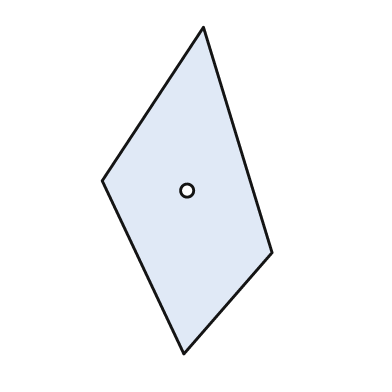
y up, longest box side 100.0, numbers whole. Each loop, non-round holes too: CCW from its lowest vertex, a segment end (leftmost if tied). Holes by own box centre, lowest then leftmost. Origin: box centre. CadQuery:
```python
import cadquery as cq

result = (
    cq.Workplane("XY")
    .moveTo(-1.0, -50.0)
    .lineTo(26.0, -19.0)
    .lineTo(5.0, 50.0)
    .lineTo(-26.0, 3.0)
    .close()
    .moveTo(0.0, 0.0)
    .circle(2.0)
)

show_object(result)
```